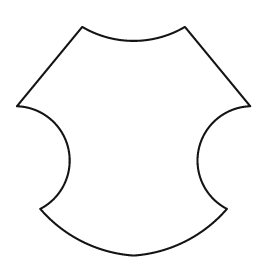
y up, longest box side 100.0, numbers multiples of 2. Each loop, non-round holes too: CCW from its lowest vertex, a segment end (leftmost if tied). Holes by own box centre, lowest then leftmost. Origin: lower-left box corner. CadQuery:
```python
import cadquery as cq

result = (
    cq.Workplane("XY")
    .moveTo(50.0, 0.0)
    .threePointArc((72.0, 6.0), (90.0, 20.0))
    .threePointArc((78.0, 46.0), (100.0, 64.0))
    .lineTo(72.0, 98.0)
    .threePointArc((50.0, 92.0), (28.0, 98.0))
    .lineTo(0.0, 64.0)
    .threePointArc((22.0, 46.0), (10.0, 20.0))
    .threePointArc((28.0, 6.0), (50.0, 0.0))
    .close()
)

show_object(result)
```